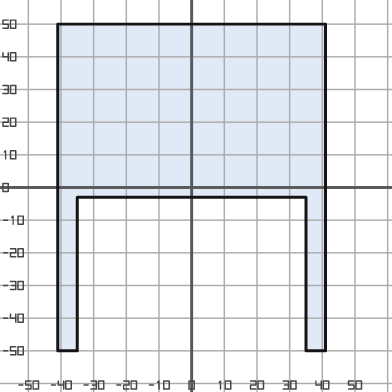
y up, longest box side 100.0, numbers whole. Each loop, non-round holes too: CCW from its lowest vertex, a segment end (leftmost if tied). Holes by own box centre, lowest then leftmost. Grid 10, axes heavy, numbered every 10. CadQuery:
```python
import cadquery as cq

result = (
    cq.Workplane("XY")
    .moveTo(-41.0, -50.0)
    .lineTo(-35.0, -50.0)
    .lineTo(-35.0, -3.0)
    .lineTo(35.0, -3.0)
    .lineTo(35.0, -50.0)
    .lineTo(41.0, -50.0)
    .lineTo(41.0, 50.0)
    .lineTo(-41.0, 50.0)
    .close()
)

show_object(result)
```